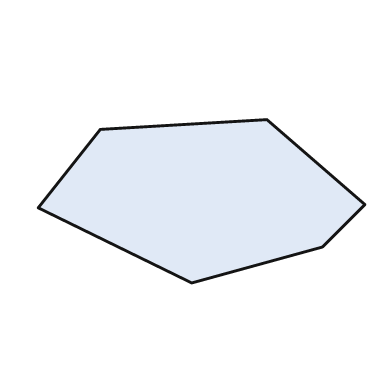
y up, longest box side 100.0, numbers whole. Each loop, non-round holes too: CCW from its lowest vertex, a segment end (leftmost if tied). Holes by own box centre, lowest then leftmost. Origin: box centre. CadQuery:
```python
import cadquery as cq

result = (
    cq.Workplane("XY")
    .moveTo(-3.0, -25.0)
    .lineTo(37.0, -14.0)
    .lineTo(50.0, -1.0)
    .lineTo(20.0, 25.0)
    .lineTo(-31.0, 22.0)
    .lineTo(-50.0, -2.0)
    .close()
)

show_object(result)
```